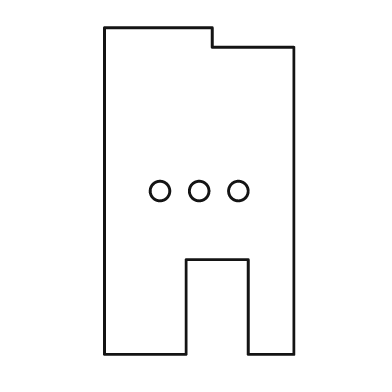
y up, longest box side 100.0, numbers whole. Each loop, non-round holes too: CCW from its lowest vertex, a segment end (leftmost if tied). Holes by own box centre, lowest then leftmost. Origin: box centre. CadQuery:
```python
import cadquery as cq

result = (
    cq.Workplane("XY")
    .moveTo(-29.0, -50.0)
    .lineTo(-4.0, -50.0)
    .lineTo(-4.0, -21.0)
    .lineTo(15.0, -21.0)
    .lineTo(15.0, -50.0)
    .lineTo(29.0, -50.0)
    .lineTo(29.0, 44.0)
    .lineTo(4.0, 44.0)
    .lineTo(4.0, 50.0)
    .lineTo(-29.0, 50.0)
    .close()
    .moveTo(-12.0, 0.0)
    .circle(3.0)
    .moveTo(0.0, 0.0)
    .circle(3.0)
    .moveTo(12.0, 0.0)
    .circle(3.0)
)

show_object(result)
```